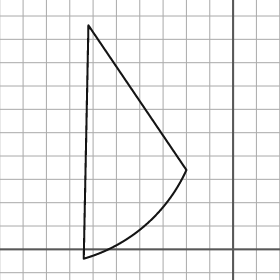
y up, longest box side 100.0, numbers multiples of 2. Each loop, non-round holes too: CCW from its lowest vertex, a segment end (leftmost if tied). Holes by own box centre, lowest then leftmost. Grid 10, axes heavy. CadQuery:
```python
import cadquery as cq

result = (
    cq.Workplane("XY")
    .moveTo(-64.0, -4.0)
    .threePointArc((-38.0, 10.0), (-20.0, 34.0))
    .lineTo(-62.0, 96.0)
    .close()
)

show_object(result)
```